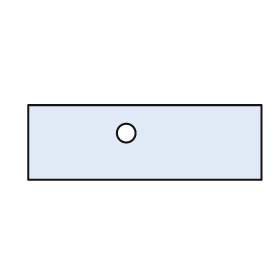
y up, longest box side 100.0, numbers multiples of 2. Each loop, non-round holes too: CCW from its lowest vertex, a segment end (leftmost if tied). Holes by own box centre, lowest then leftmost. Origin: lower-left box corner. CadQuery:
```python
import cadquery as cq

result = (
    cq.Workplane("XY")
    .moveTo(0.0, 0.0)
    .lineTo(100.0, 0.0)
    .lineTo(100.0, 32.0)
    .lineTo(0.0, 32.0)
    .close()
    .moveTo(42.0, 20.0)
    .circle(4.0)
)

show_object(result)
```